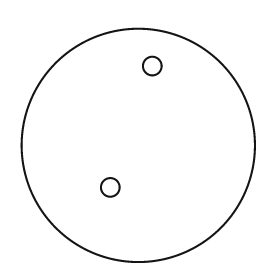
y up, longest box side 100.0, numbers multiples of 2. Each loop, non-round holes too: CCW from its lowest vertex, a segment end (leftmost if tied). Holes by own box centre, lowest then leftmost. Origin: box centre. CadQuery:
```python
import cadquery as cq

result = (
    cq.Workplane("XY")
    .moveTo(0.0, 0.0)
    .circle(50.0)
    .moveTo(-12.0, -18.0)
    .circle(4.0)
    .moveTo(6.0, 34.0)
    .circle(4.0)
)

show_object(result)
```